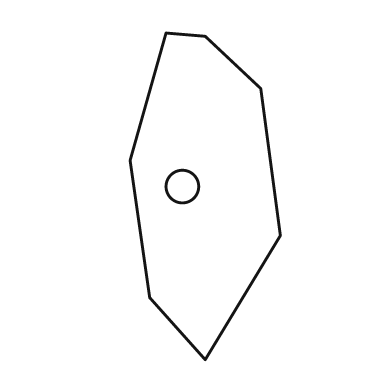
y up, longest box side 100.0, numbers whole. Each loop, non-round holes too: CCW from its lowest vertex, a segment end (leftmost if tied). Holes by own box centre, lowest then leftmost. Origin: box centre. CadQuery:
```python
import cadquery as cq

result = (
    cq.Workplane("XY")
    .moveTo(0.0, -50.0)
    .lineTo(23.0, -12.0)
    .lineTo(17.0, 33.0)
    .lineTo(0.0, 49.0)
    .lineTo(-12.0, 50.0)
    .lineTo(-23.0, 11.0)
    .lineTo(-17.0, -31.0)
    .close()
    .moveTo(-7.0, 3.0)
    .circle(5.0)
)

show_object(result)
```